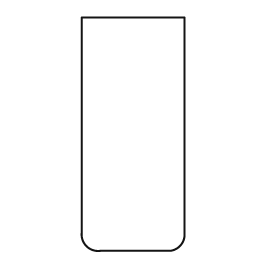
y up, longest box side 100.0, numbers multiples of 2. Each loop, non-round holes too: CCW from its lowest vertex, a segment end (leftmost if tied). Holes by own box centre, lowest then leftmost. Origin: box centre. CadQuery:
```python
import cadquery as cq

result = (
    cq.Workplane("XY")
    .moveTo(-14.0, -50.0)
    .lineTo(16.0, -50.0)
    .threePointArc((20.0, -48.0), (22.0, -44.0))
    .lineTo(22.0, 50.0)
    .lineTo(-22.0, 50.0)
    .lineTo(-22.0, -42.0)
    .threePointArc((-20.0, -48.0), (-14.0, -50.0))
    .close()
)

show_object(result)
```